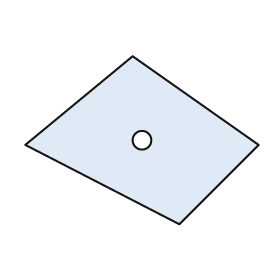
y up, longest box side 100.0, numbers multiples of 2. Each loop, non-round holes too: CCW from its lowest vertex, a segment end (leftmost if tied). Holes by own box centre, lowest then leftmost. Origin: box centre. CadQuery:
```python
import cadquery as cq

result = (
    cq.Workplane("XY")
    .moveTo(16.0, -36.0)
    .lineTo(50.0, -2.0)
    .lineTo(-4.0, 36.0)
    .lineTo(-50.0, -2.0)
    .close()
    .moveTo(0.0, 0.0)
    .circle(4.0)
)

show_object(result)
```